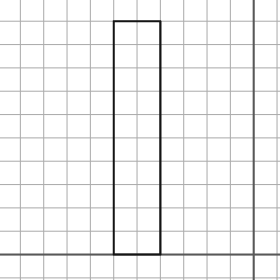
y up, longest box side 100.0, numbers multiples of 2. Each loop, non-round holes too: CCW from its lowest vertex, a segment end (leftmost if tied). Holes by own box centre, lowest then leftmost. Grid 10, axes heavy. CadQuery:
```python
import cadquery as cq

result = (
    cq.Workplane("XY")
    .moveTo(-60.0, 0.0)
    .lineTo(-40.0, 0.0)
    .lineTo(-40.0, 100.0)
    .lineTo(-60.0, 100.0)
    .close()
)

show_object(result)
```